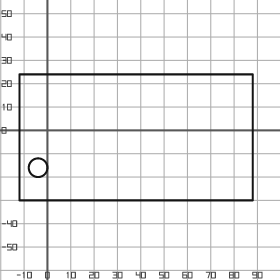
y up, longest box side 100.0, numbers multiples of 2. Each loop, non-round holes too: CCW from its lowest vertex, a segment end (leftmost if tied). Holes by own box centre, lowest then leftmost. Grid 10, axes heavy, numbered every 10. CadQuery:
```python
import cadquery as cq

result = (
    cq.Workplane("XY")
    .moveTo(-12.0, -30.0)
    .lineTo(88.0, -30.0)
    .lineTo(88.0, 24.0)
    .lineTo(-12.0, 24.0)
    .close()
    .moveTo(-4.0, -16.0)
    .circle(4.0)
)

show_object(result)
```